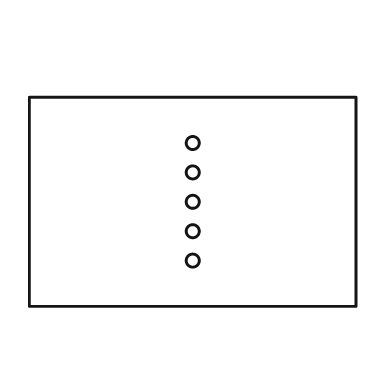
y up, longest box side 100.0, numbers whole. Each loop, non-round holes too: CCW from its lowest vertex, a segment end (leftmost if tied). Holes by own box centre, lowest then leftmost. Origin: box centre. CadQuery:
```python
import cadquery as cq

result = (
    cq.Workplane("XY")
    .moveTo(-50.0, -32.0)
    .lineTo(50.0, -32.0)
    .lineTo(50.0, 32.0)
    .lineTo(-50.0, 32.0)
    .close()
    .moveTo(0.0, -18.0)
    .circle(2.0)
    .moveTo(0.0, -9.0)
    .circle(2.0)
    .moveTo(0.0, 0.0)
    .circle(2.0)
    .moveTo(0.0, 9.0)
    .circle(2.0)
    .moveTo(0.0, 18.0)
    .circle(2.0)
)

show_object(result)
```